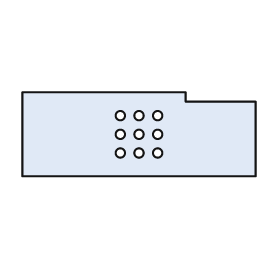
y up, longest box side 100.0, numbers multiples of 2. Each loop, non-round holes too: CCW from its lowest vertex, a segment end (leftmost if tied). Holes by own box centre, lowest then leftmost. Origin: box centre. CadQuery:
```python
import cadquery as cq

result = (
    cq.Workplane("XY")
    .moveTo(-50.0, -18.0)
    .lineTo(50.0, -18.0)
    .lineTo(50.0, 14.0)
    .lineTo(20.0, 14.0)
    .lineTo(20.0, 18.0)
    .lineTo(-50.0, 18.0)
    .close()
    .moveTo(-8.0, -8.0)
    .circle(2.0)
    .moveTo(0.0, -8.0)
    .circle(2.0)
    .moveTo(8.0, -8.0)
    .circle(2.0)
    .moveTo(-8.0, 0.0)
    .circle(2.0)
    .moveTo(0.0, 0.0)
    .circle(2.0)
    .moveTo(8.0, 0.0)
    .circle(2.0)
    .moveTo(-8.0, 8.0)
    .circle(2.0)
    .moveTo(0.0, 8.0)
    .circle(2.0)
    .moveTo(8.0, 8.0)
    .circle(2.0)
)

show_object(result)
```